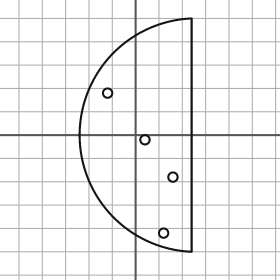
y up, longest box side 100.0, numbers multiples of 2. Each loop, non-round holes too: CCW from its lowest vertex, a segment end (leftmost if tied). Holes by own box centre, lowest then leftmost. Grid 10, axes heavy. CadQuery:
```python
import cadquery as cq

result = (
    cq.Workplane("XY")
    .moveTo(24.0, -50.0)
    .lineTo(24.0, 50.0)
    .threePointArc((-24.0, 0.0), (24.0, -50.0))
    .close()
    .moveTo(12.0, -42.0)
    .circle(2.0)
    .moveTo(16.0, -18.0)
    .circle(2.0)
    .moveTo(4.0, -2.0)
    .circle(2.0)
    .moveTo(-12.0, 18.0)
    .circle(2.0)
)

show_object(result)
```